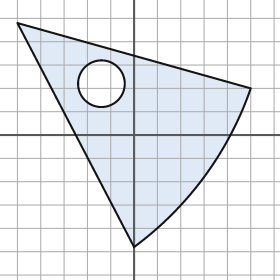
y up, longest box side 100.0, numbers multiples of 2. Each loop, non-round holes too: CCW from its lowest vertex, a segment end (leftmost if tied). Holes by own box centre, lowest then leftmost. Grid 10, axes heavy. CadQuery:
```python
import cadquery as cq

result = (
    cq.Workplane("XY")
    .moveTo(0.0, -48.0)
    .threePointArc((30.0, -18.0), (50.0, 20.0))
    .lineTo(-50.0, 48.0)
    .close()
    .moveTo(-14.0, 22.0)
    .circle(10.0)
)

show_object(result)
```